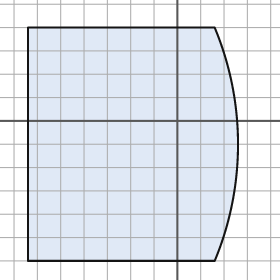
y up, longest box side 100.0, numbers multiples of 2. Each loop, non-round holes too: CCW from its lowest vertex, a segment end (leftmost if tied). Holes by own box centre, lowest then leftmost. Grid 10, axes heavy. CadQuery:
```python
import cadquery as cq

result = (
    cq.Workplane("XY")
    .moveTo(-64.0, -60.0)
    .lineTo(16.0, -60.0)
    .threePointArc((26.0, -10.0), (16.0, 40.0))
    .lineTo(-64.0, 40.0)
    .close()
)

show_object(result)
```